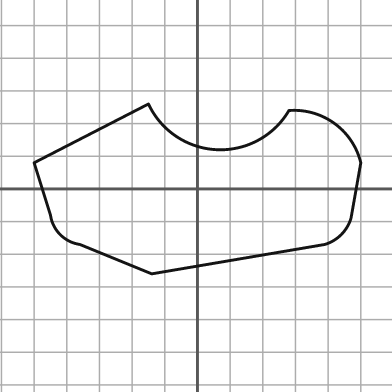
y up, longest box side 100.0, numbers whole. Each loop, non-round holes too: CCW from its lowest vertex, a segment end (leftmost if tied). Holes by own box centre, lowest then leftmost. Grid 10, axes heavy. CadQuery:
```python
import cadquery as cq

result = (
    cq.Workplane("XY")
    .moveTo(-14.0, -26.0)
    .lineTo(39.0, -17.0)
    .threePointArc((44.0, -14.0), (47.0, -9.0))
    .lineTo(50.0, 8.0)
    .threePointArc((42.0, 20.0), (28.0, 24.0))
    .threePointArc((6.0, 12.0), (-15.0, 26.0))
    .lineTo(-50.0, 8.0)
    .lineTo(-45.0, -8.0)
    .threePointArc((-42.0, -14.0), (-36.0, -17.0))
    .close()
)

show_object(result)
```